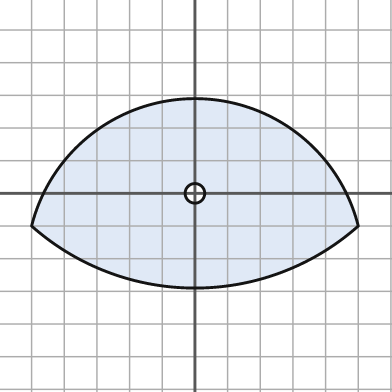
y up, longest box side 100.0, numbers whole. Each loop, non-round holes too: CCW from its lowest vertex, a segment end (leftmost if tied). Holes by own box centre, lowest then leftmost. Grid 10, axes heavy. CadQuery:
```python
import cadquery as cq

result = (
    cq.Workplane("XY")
    .moveTo(-50.0, -10.0)
    .threePointArc((0.0, -29.0), (50.0, -10.0))
    .threePointArc((0.0, 29.0), (-50.0, -10.0))
    .close()
    .moveTo(0.0, 0.0)
    .circle(3.0)
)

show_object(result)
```